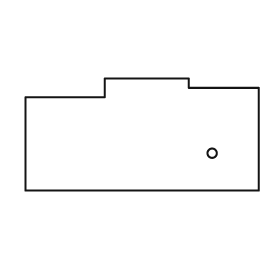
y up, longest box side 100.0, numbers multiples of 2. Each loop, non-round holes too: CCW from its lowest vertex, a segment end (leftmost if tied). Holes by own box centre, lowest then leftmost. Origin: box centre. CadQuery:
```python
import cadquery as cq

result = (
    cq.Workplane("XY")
    .moveTo(-50.0, -24.0)
    .lineTo(50.0, -24.0)
    .lineTo(50.0, 20.0)
    .lineTo(20.0, 20.0)
    .lineTo(20.0, 24.0)
    .lineTo(-16.0, 24.0)
    .lineTo(-16.0, 16.0)
    .lineTo(-50.0, 16.0)
    .close()
    .moveTo(30.0, -8.0)
    .circle(2.0)
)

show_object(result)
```